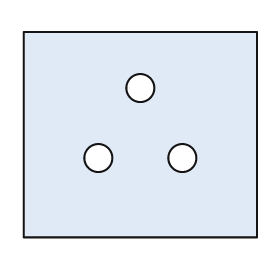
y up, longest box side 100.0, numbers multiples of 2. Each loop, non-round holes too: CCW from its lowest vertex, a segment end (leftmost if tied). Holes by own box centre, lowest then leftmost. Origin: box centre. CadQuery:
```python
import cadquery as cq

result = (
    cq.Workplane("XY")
    .moveTo(-50.0, -44.0)
    .lineTo(50.0, -44.0)
    .lineTo(50.0, 44.0)
    .lineTo(-50.0, 44.0)
    .close()
    .moveTo(-18.0, -10.0)
    .circle(6.0)
    .moveTo(18.0, -10.0)
    .circle(6.0)
    .moveTo(0.0, 20.0)
    .circle(6.0)
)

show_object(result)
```